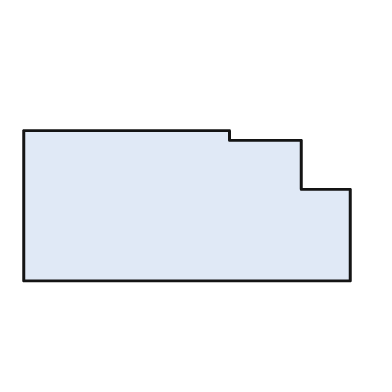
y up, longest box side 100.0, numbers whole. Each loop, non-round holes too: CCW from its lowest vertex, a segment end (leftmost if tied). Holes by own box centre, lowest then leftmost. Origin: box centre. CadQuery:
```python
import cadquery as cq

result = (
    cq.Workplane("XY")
    .moveTo(-50.0, -23.0)
    .lineTo(50.0, -23.0)
    .lineTo(50.0, 5.0)
    .lineTo(35.0, 5.0)
    .lineTo(35.0, 20.0)
    .lineTo(13.0, 20.0)
    .lineTo(13.0, 23.0)
    .lineTo(-50.0, 23.0)
    .close()
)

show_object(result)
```